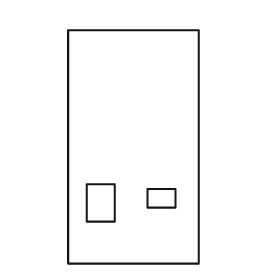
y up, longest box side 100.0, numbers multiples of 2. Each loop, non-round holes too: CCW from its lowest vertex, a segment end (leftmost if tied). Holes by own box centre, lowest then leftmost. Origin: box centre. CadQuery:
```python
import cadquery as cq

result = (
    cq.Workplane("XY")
    .moveTo(-28.0, -50.0)
    .lineTo(28.0, -50.0)
    .lineTo(28.0, 50.0)
    .lineTo(-28.0, 50.0)
    .close()
    .moveTo(-20.0, -32.0)
    .lineTo(-8.0, -32.0)
    .lineTo(-8.0, -16.0)
    .lineTo(-20.0, -16.0)
    .close()
    .moveTo(6.0, -26.0)
    .lineTo(18.0, -26.0)
    .lineTo(18.0, -18.0)
    .lineTo(6.0, -18.0)
    .close()
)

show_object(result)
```